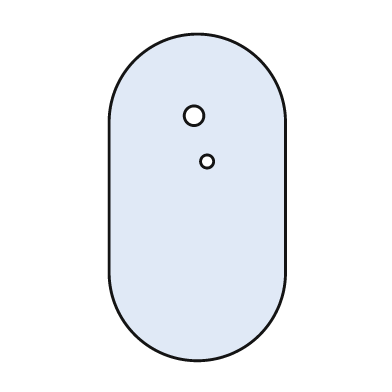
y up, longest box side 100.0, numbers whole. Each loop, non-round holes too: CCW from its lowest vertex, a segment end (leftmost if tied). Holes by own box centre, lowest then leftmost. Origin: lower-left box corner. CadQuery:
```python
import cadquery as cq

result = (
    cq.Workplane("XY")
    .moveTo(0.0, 27.0)
    .threePointArc((27.0, 0.0), (54.0, 27.0))
    .lineTo(54.0, 73.0)
    .threePointArc((27.0, 100.0), (0.0, 73.0))
    .close()
    .moveTo(30.0, 61.0)
    .circle(2.0)
    .moveTo(26.0, 75.0)
    .circle(3.0)
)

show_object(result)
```